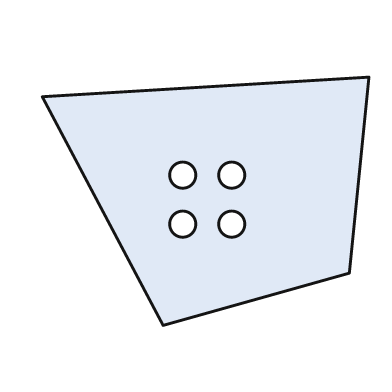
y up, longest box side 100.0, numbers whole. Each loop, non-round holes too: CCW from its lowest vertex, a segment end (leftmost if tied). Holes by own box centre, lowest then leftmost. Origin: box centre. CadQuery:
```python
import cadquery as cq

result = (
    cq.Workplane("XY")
    .moveTo(-13.0, -38.0)
    .lineTo(44.0, -22.0)
    .lineTo(50.0, 38.0)
    .lineTo(-50.0, 32.0)
    .close()
    .moveTo(-7.0, -7.0)
    .circle(4.0)
    .moveTo(8.0, -7.0)
    .circle(4.0)
    .moveTo(-7.0, 8.0)
    .circle(4.0)
    .moveTo(8.0, 8.0)
    .circle(4.0)
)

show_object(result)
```